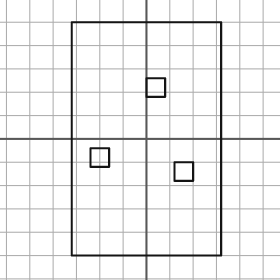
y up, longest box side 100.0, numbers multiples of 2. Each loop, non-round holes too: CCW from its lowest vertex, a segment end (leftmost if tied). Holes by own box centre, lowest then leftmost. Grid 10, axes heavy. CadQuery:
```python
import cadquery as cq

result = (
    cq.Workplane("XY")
    .moveTo(-32.0, -50.0)
    .lineTo(32.0, -50.0)
    .lineTo(32.0, 50.0)
    .lineTo(-32.0, 50.0)
    .close()
    .moveTo(12.0, -18.0)
    .lineTo(20.0, -18.0)
    .lineTo(20.0, -10.0)
    .lineTo(12.0, -10.0)
    .close()
    .moveTo(-24.0, -12.0)
    .lineTo(-16.0, -12.0)
    .lineTo(-16.0, -4.0)
    .lineTo(-24.0, -4.0)
    .close()
    .moveTo(0.0, 18.0)
    .lineTo(8.0, 18.0)
    .lineTo(8.0, 26.0)
    .lineTo(0.0, 26.0)
    .close()
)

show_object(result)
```